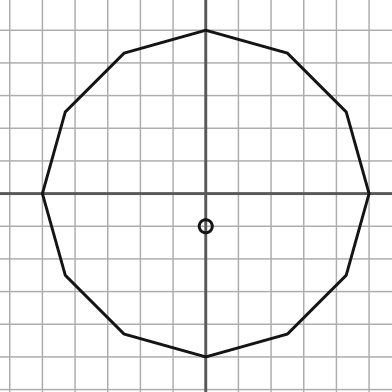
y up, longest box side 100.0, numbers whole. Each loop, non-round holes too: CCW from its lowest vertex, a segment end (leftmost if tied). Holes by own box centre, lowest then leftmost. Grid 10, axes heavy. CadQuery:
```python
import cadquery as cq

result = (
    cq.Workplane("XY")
    .moveTo(0.0, -50.0)
    .lineTo(25.0, -43.0)
    .lineTo(43.0, -25.0)
    .lineTo(50.0, 0.0)
    .lineTo(43.0, 25.0)
    .lineTo(25.0, 43.0)
    .lineTo(0.0, 50.0)
    .lineTo(-25.0, 43.0)
    .lineTo(-43.0, 25.0)
    .lineTo(-50.0, 0.0)
    .lineTo(-43.0, -25.0)
    .lineTo(-25.0, -43.0)
    .close()
    .moveTo(0.0, -10.0)
    .circle(2.0)
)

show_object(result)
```